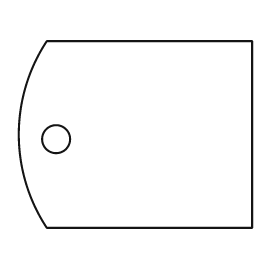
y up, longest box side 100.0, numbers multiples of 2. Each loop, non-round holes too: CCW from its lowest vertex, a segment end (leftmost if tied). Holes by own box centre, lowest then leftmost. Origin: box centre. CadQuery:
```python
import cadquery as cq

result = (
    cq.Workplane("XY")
    .moveTo(-38.0, -40.0)
    .lineTo(50.0, -40.0)
    .lineTo(50.0, 40.0)
    .lineTo(-38.0, 40.0)
    .threePointArc((-50.0, 0.0), (-38.0, -40.0))
    .close()
    .moveTo(-34.0, -2.0)
    .circle(6.0)
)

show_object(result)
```